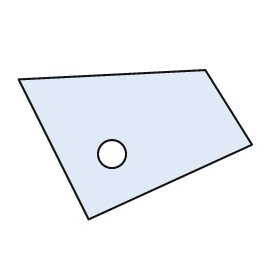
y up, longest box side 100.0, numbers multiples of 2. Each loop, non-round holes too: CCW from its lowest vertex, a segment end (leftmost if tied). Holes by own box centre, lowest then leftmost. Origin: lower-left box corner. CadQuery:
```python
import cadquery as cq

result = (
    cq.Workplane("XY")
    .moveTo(30.0, 0.0)
    .lineTo(100.0, 32.0)
    .lineTo(80.0, 64.0)
    .lineTo(0.0, 60.0)
    .close()
    .moveTo(40.0, 28.0)
    .circle(6.0)
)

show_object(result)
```